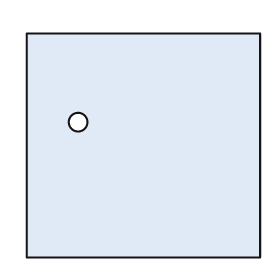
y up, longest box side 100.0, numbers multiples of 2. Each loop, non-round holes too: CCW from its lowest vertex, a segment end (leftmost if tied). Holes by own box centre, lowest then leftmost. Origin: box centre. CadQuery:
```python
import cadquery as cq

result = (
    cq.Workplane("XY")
    .moveTo(-50.0, -48.0)
    .lineTo(50.0, -48.0)
    .lineTo(50.0, 48.0)
    .lineTo(-50.0, 48.0)
    .close()
    .moveTo(-28.0, 10.0)
    .circle(4.0)
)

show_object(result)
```